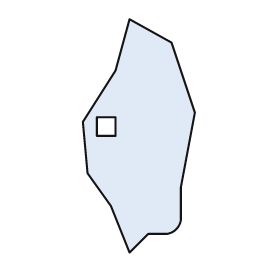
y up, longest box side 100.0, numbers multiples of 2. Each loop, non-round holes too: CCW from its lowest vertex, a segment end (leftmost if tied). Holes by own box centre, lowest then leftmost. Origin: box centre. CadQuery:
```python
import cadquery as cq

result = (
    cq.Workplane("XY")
    .moveTo(-4.0, -50.0)
    .lineTo(4.0, -42.0)
    .lineTo(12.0, -42.0)
    .threePointArc((16.0, -40.0), (18.0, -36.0))
    .lineTo(18.0, -22.0)
    .lineTo(24.0, 10.0)
    .lineTo(14.0, 40.0)
    .lineTo(-4.0, 50.0)
    .lineTo(-10.0, 28.0)
    .lineTo(-24.0, 6.0)
    .lineTo(-22.0, -16.0)
    .lineTo(-12.0, -30.0)
    .close()
    .moveTo(-18.0, 0.0)
    .lineTo(-10.0, 0.0)
    .lineTo(-10.0, 8.0)
    .lineTo(-18.0, 8.0)
    .close()
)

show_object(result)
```